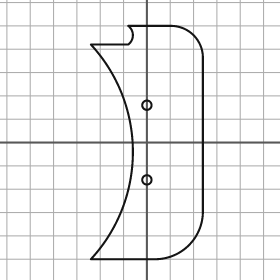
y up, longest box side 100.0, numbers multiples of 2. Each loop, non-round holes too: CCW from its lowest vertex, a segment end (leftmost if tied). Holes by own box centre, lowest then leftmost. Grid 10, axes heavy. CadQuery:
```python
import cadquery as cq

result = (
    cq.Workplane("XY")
    .moveTo(-24.0, -50.0)
    .lineTo(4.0, -50.0)
    .threePointArc((18.0, -44.0), (24.0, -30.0))
    .lineTo(24.0, 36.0)
    .threePointArc((20.0, 46.0), (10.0, 50.0))
    .lineTo(-8.0, 50.0)
    .threePointArc((-6.0, 46.0), (-8.0, 42.0))
    .lineTo(-24.0, 42.0)
    .threePointArc((-6.0, -4.0), (-24.0, -50.0))
    .close()
    .moveTo(0.0, -16.0)
    .circle(2.0)
    .moveTo(0.0, 16.0)
    .circle(2.0)
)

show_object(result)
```